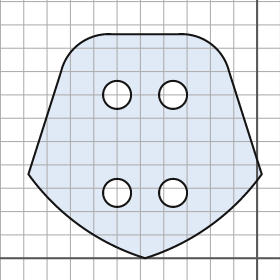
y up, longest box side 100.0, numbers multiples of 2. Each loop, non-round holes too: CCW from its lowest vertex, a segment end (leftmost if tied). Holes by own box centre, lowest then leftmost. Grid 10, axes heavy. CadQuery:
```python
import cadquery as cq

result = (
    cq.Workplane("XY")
    .moveTo(-48.0, 0.0)
    .threePointArc((-20.0, 14.0), (2.0, 36.0))
    .lineTo(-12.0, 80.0)
    .threePointArc((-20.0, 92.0), (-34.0, 96.0))
    .lineTo(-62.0, 96.0)
    .threePointArc((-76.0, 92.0), (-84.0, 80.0))
    .lineTo(-98.0, 36.0)
    .threePointArc((-76.0, 14.0), (-48.0, 0.0))
    .close()
    .moveTo(-60.0, 28.0)
    .circle(6.0)
    .moveTo(-36.0, 28.0)
    .circle(6.0)
    .moveTo(-60.0, 70.0)
    .circle(6.0)
    .moveTo(-36.0, 70.0)
    .circle(6.0)
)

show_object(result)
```